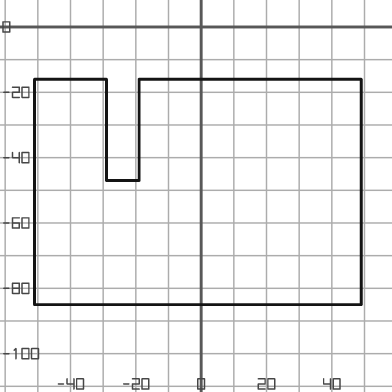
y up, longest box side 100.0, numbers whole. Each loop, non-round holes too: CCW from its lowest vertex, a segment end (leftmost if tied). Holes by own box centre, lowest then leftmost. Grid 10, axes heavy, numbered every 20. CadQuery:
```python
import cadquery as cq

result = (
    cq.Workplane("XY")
    .moveTo(-51.0, -85.0)
    .lineTo(49.0, -85.0)
    .lineTo(49.0, -16.0)
    .lineTo(-19.0, -16.0)
    .lineTo(-19.0, -47.0)
    .lineTo(-29.0, -47.0)
    .lineTo(-29.0, -16.0)
    .lineTo(-51.0, -16.0)
    .close()
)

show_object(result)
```